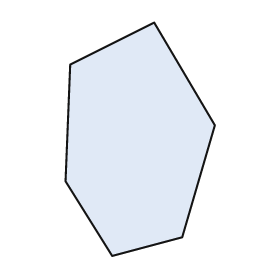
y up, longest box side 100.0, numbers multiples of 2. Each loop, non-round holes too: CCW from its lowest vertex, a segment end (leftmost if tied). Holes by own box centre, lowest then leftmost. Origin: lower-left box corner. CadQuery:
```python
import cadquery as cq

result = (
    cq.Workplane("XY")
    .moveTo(20.0, 0.0)
    .lineTo(50.0, 8.0)
    .lineTo(64.0, 56.0)
    .lineTo(38.0, 100.0)
    .lineTo(2.0, 82.0)
    .lineTo(0.0, 32.0)
    .close()
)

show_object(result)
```